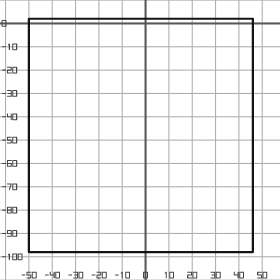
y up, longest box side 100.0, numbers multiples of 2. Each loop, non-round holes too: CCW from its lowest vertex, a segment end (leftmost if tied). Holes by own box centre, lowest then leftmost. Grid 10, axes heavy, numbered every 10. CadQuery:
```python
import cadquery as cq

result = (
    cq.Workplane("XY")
    .moveTo(-50.0, -98.0)
    .lineTo(46.0, -98.0)
    .lineTo(46.0, 2.0)
    .lineTo(-50.0, 2.0)
    .close()
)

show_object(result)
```